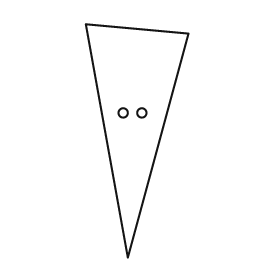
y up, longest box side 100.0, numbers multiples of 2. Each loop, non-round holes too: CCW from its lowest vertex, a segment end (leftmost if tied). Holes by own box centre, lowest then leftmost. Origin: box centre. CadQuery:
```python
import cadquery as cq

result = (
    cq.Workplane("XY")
    .moveTo(-4.0, -50.0)
    .lineTo(22.0, 46.0)
    .lineTo(-22.0, 50.0)
    .close()
    .moveTo(-6.0, 12.0)
    .circle(2.0)
    .moveTo(2.0, 12.0)
    .circle(2.0)
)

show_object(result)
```